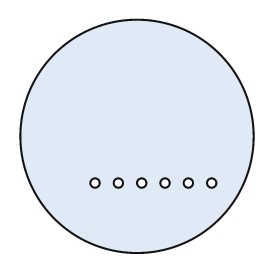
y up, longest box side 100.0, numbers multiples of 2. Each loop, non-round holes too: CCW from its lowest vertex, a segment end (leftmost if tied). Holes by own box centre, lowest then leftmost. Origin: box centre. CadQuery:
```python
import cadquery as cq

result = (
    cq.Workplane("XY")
    .moveTo(0.0, 0.0)
    .circle(50.0)
    .moveTo(-18.0, -20.0)
    .circle(2.0)
    .moveTo(-8.0, -20.0)
    .circle(2.0)
    .moveTo(2.0, -20.0)
    .circle(2.0)
    .moveTo(12.0, -20.0)
    .circle(2.0)
    .moveTo(22.0, -20.0)
    .circle(2.0)
    .moveTo(32.0, -20.0)
    .circle(2.0)
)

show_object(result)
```